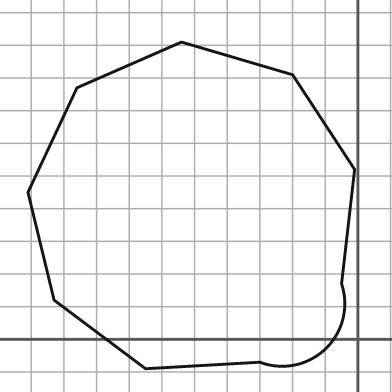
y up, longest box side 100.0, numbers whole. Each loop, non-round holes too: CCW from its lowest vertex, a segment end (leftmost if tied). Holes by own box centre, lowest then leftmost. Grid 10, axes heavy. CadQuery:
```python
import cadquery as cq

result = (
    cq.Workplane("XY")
    .moveTo(-65.0, -9.0)
    .lineTo(-30.0, -7.0)
    .threePointArc((-10.0, -3.0), (-5.0, 17.0))
    .lineTo(-1.0, 52.0)
    .lineTo(-20.0, 81.0)
    .lineTo(-54.0, 91.0)
    .lineTo(-86.0, 77.0)
    .lineTo(-101.0, 45.0)
    .lineTo(-93.0, 12.0)
    .close()
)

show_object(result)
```